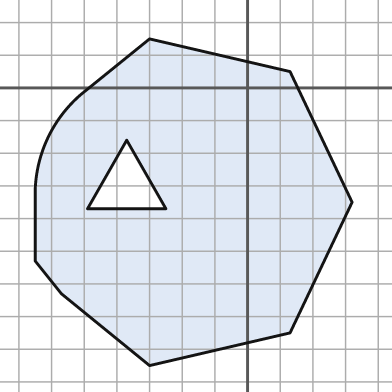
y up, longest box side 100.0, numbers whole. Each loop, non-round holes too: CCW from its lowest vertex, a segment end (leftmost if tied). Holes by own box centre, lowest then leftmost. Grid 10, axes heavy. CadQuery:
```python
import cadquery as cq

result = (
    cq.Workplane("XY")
    .moveTo(-30.0, -85.0)
    .lineTo(13.0, -75.0)
    .lineTo(32.0, -35.0)
    .lineTo(13.0, 5.0)
    .lineTo(-30.0, 15.0)
    .lineTo(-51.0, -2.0)
    .threePointArc((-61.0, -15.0), (-65.0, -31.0))
    .lineTo(-65.0, -53.0)
    .lineTo(-57.0, -63.0)
    .close()
    .moveTo(-49.0, -37.0)
    .lineTo(-25.0, -37.0)
    .lineTo(-37.0, -16.0)
    .close()
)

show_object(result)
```